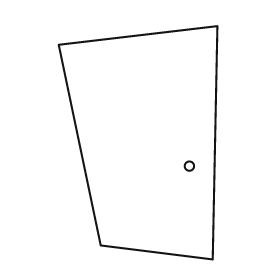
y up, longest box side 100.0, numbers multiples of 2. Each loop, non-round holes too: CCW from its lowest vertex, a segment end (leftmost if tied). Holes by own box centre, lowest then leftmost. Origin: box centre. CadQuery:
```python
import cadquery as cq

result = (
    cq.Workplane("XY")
    .moveTo(32.0, -50.0)
    .lineTo(34.0, 50.0)
    .lineTo(-34.0, 42.0)
    .lineTo(-16.0, -44.0)
    .close()
    .moveTo(22.0, -10.0)
    .circle(2.0)
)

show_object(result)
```